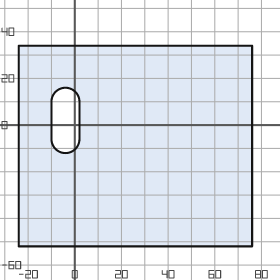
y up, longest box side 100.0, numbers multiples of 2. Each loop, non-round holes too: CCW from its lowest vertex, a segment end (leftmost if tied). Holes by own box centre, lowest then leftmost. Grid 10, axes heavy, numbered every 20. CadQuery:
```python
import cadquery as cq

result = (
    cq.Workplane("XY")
    .moveTo(-24.0, -52.0)
    .lineTo(76.0, -52.0)
    .lineTo(76.0, 34.0)
    .lineTo(-24.0, 34.0)
    .close()
    .moveTo(-10.0, -6.0)
    .threePointArc((-4.0, -12.0), (2.0, -6.0))
    .lineTo(2.0, 10.0)
    .threePointArc((-4.0, 16.0), (-10.0, 10.0))
    .close()
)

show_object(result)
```